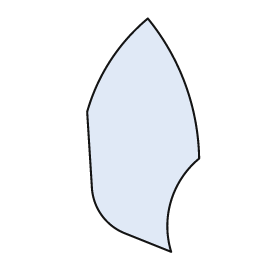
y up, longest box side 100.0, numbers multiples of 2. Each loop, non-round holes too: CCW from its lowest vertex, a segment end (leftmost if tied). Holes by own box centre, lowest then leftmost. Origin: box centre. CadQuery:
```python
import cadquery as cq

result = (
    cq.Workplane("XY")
    .moveTo(12.0, -50.0)
    .threePointArc((12.0, -28.0), (24.0, -10.0))
    .threePointArc((18.0, 22.0), (2.0, 50.0))
    .threePointArc((-14.0, 32.0), (-24.0, 10.0))
    .lineTo(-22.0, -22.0)
    .threePointArc((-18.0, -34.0), (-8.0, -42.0))
    .close()
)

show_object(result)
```